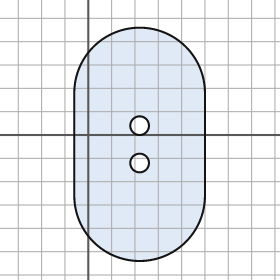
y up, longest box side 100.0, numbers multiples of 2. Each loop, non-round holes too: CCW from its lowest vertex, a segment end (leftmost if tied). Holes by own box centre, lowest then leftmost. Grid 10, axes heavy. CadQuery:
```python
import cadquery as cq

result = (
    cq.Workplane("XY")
    .moveTo(-6.0, -26.0)
    .threePointArc((22.0, -54.0), (50.0, -26.0))
    .lineTo(50.0, 18.0)
    .threePointArc((22.0, 46.0), (-6.0, 18.0))
    .close()
    .moveTo(22.0, -12.0)
    .circle(4.0)
    .moveTo(22.0, 4.0)
    .circle(4.0)
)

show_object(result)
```